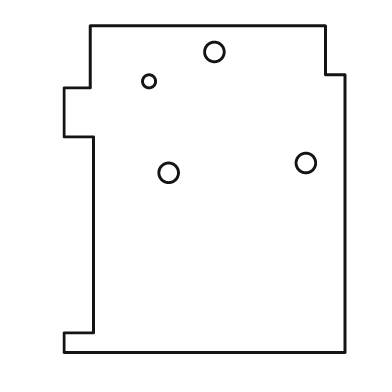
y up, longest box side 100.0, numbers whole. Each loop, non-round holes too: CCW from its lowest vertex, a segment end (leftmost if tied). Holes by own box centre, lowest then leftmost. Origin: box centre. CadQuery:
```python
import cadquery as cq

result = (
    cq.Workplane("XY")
    .moveTo(-43.0, -50.0)
    .lineTo(43.0, -50.0)
    .lineTo(43.0, 35.0)
    .lineTo(37.0, 35.0)
    .lineTo(37.0, 50.0)
    .lineTo(-35.0, 50.0)
    .lineTo(-35.0, 31.0)
    .lineTo(-43.0, 31.0)
    .lineTo(-43.0, 16.0)
    .lineTo(-34.0, 16.0)
    .lineTo(-34.0, -44.0)
    .lineTo(-43.0, -44.0)
    .close()
    .moveTo(-11.0, 5.0)
    .circle(3.0)
    .moveTo(31.0, 8.0)
    .circle(3.0)
    .moveTo(-17.0, 33.0)
    .circle(2.0)
    .moveTo(3.0, 42.0)
    .circle(3.0)
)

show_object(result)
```